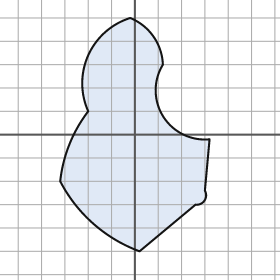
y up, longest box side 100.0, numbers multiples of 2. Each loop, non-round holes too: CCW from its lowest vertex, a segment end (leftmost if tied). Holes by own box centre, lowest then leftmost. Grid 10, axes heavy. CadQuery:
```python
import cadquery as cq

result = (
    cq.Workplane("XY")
    .moveTo(2.0, -50.0)
    .lineTo(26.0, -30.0)
    .threePointArc((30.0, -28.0), (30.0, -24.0))
    .lineTo(32.0, -2.0)
    .threePointArc((12.0, 8.0), (12.0, 30.0))
    .threePointArc((8.0, 42.0), (-2.0, 50.0))
    .threePointArc((-20.0, 34.0), (-20.0, 10.0))
    .threePointArc((-28.0, -4.0), (-32.0, -20.0))
    .threePointArc((-18.0, -38.0), (2.0, -50.0))
    .close()
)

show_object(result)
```